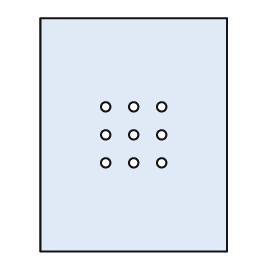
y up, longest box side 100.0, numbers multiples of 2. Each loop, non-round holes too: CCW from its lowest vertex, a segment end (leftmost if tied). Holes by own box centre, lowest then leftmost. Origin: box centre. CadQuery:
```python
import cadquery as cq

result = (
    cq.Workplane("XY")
    .moveTo(-40.0, -50.0)
    .lineTo(40.0, -50.0)
    .lineTo(40.0, 50.0)
    .lineTo(-40.0, 50.0)
    .close()
    .moveTo(-12.0, -12.0)
    .circle(2.0)
    .moveTo(0.0, -12.0)
    .circle(2.0)
    .moveTo(12.0, -12.0)
    .circle(2.0)
    .moveTo(-12.0, 0.0)
    .circle(2.0)
    .moveTo(0.0, 0.0)
    .circle(2.0)
    .moveTo(12.0, 0.0)
    .circle(2.0)
    .moveTo(-12.0, 12.0)
    .circle(2.0)
    .moveTo(0.0, 12.0)
    .circle(2.0)
    .moveTo(12.0, 12.0)
    .circle(2.0)
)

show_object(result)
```